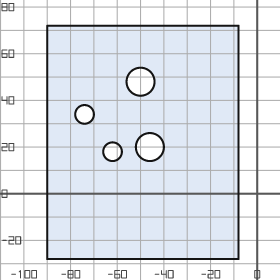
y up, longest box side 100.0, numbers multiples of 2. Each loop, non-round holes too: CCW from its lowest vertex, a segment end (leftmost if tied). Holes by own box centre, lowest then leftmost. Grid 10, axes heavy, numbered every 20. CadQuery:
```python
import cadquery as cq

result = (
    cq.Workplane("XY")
    .moveTo(-90.0, -28.0)
    .lineTo(-8.0, -28.0)
    .lineTo(-8.0, 72.0)
    .lineTo(-90.0, 72.0)
    .close()
    .moveTo(-62.0, 18.0)
    .circle(4.0)
    .moveTo(-46.0, 20.0)
    .circle(6.0)
    .moveTo(-74.0, 34.0)
    .circle(4.0)
    .moveTo(-50.0, 48.0)
    .circle(6.0)
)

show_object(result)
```